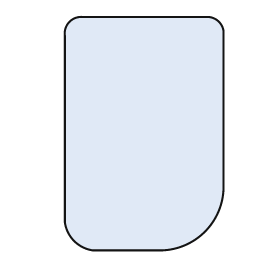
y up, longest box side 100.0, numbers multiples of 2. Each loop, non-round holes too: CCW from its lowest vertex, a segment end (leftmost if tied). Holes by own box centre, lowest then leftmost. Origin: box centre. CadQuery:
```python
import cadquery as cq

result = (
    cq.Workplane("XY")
    .moveTo(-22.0, -50.0)
    .lineTo(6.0, -50.0)
    .threePointArc((26.0, -42.0), (34.0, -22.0))
    .lineTo(34.0, 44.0)
    .threePointArc((32.0, 48.0), (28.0, 50.0))
    .lineTo(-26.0, 50.0)
    .threePointArc((-32.0, 48.0), (-34.0, 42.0))
    .lineTo(-34.0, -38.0)
    .threePointArc((-30.0, -46.0), (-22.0, -50.0))
    .close()
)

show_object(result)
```